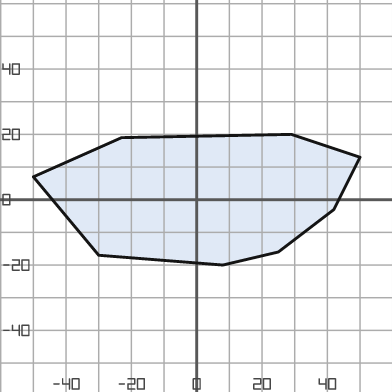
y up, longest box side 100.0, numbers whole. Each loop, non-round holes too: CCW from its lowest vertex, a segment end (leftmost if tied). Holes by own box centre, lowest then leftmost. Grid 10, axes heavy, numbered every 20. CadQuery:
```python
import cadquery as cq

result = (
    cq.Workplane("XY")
    .moveTo(8.0, -20.0)
    .lineTo(25.0, -16.0)
    .lineTo(42.0, -3.0)
    .lineTo(50.0, 13.0)
    .lineTo(29.0, 20.0)
    .lineTo(-23.0, 19.0)
    .lineTo(-50.0, 7.0)
    .lineTo(-30.0, -17.0)
    .close()
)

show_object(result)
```